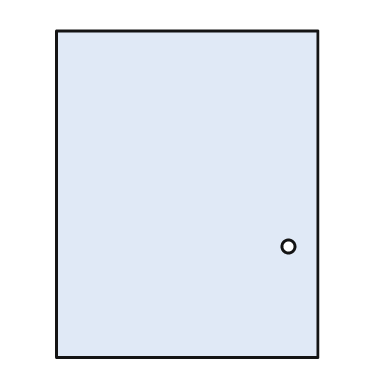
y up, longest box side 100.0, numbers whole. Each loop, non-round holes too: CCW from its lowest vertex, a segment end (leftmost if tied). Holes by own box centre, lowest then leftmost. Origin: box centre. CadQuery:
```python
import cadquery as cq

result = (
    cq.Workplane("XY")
    .moveTo(-40.0, -50.0)
    .lineTo(40.0, -50.0)
    .lineTo(40.0, 50.0)
    .lineTo(-40.0, 50.0)
    .close()
    .moveTo(31.0, -16.0)
    .circle(2.0)
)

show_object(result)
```